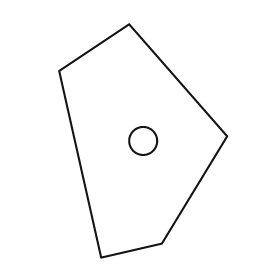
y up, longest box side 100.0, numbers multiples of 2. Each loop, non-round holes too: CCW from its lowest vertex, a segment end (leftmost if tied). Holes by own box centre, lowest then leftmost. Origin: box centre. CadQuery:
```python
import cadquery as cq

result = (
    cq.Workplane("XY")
    .moveTo(-18.0, -50.0)
    .lineTo(8.0, -44.0)
    .lineTo(36.0, 2.0)
    .lineTo(-6.0, 50.0)
    .lineTo(-36.0, 30.0)
    .close()
    .moveTo(0.0, 0.0)
    .circle(6.0)
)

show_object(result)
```